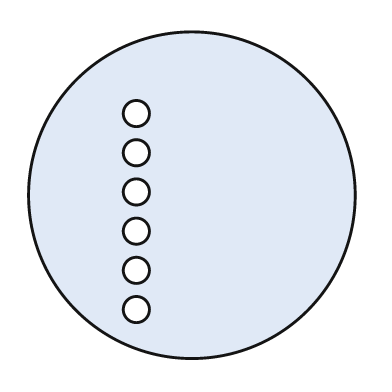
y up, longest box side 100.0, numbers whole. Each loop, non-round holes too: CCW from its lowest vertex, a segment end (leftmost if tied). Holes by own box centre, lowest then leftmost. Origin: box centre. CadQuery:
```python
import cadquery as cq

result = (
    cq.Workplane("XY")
    .moveTo(0.0, 0.0)
    .circle(50.0)
    .moveTo(-17.0, -35.0)
    .circle(4.0)
    .moveTo(-17.0, -23.0)
    .circle(4.0)
    .moveTo(-17.0, -11.0)
    .circle(4.0)
    .moveTo(-17.0, 1.0)
    .circle(4.0)
    .moveTo(-17.0, 13.0)
    .circle(4.0)
    .moveTo(-17.0, 25.0)
    .circle(4.0)
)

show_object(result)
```